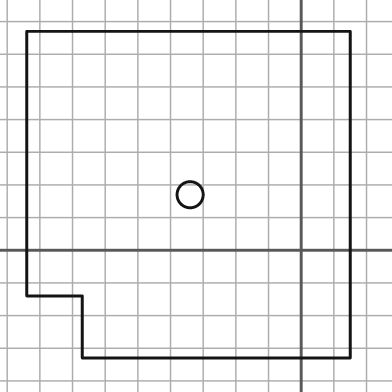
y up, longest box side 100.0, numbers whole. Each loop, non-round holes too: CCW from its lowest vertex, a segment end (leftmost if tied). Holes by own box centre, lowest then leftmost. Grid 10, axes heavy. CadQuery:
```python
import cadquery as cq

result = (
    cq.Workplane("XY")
    .moveTo(-67.0, -33.0)
    .lineTo(15.0, -33.0)
    .lineTo(15.0, 67.0)
    .lineTo(-84.0, 67.0)
    .lineTo(-84.0, -14.0)
    .lineTo(-67.0, -14.0)
    .close()
    .moveTo(-34.0, 17.0)
    .circle(4.0)
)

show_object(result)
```